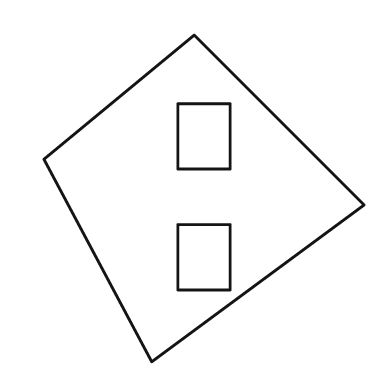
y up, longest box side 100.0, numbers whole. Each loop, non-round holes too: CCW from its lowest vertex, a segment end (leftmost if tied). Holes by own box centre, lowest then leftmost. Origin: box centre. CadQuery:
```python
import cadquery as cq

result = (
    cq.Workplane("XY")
    .moveTo(-16.0, -50.0)
    .lineTo(49.0, -2.0)
    .lineTo(-3.0, 50.0)
    .lineTo(-49.0, 12.0)
    .close()
    .moveTo(-8.0, -28.0)
    .lineTo(8.0, -28.0)
    .lineTo(8.0, -8.0)
    .lineTo(-8.0, -8.0)
    .close()
    .moveTo(-8.0, 9.0)
    .lineTo(8.0, 9.0)
    .lineTo(8.0, 29.0)
    .lineTo(-8.0, 29.0)
    .close()
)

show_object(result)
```